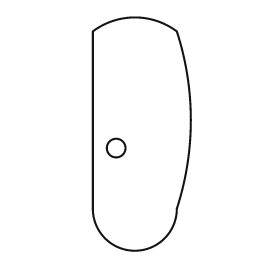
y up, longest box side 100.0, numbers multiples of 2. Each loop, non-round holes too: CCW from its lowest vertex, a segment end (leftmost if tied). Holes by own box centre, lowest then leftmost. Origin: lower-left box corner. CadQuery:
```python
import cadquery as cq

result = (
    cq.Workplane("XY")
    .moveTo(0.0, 18.0)
    .threePointArc((18.0, 0.0), (36.0, 18.0))
    .threePointArc((42.0, 56.0), (36.0, 94.0))
    .threePointArc((18.0, 100.0), (0.0, 94.0))
    .close()
    .moveTo(10.0, 44.0)
    .circle(4.0)
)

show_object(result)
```